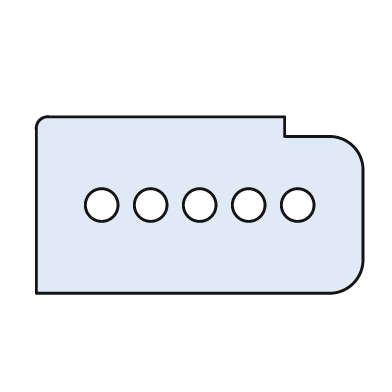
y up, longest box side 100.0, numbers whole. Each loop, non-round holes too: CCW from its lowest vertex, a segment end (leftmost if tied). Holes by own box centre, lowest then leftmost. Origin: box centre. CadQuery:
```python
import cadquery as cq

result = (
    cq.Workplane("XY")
    .moveTo(-50.0, -27.0)
    .lineTo(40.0, -27.0)
    .threePointArc((47.0, -24.0), (50.0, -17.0))
    .lineTo(50.0, 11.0)
    .threePointArc((47.0, 18.0), (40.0, 21.0))
    .lineTo(26.0, 21.0)
    .lineTo(26.0, 27.0)
    .lineTo(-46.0, 27.0)
    .threePointArc((-49.0, 26.0), (-50.0, 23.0))
    .close()
    .moveTo(-30.0, 0.0)
    .circle(5.0)
    .moveTo(-15.0, 0.0)
    .circle(5.0)
    .moveTo(0.0, 0.0)
    .circle(5.0)
    .moveTo(15.0, 0.0)
    .circle(5.0)
    .moveTo(30.0, 0.0)
    .circle(5.0)
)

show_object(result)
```